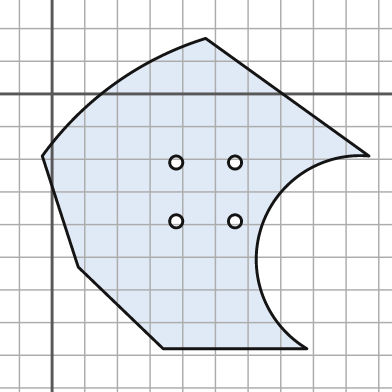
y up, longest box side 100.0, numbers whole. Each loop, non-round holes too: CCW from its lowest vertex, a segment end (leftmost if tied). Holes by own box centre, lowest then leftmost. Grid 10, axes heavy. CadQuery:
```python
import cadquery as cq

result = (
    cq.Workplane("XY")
    .moveTo(34.0, -78.0)
    .lineTo(78.0, -78.0)
    .threePointArc((64.0, -41.0), (97.0, -19.0))
    .lineTo(47.0, 17.0)
    .threePointArc((19.0, 3.0), (-3.0, -19.0))
    .lineTo(8.0, -53.0)
    .close()
    .moveTo(38.0, -39.0)
    .circle(2.0)
    .moveTo(56.0, -39.0)
    .circle(2.0)
    .moveTo(38.0, -21.0)
    .circle(2.0)
    .moveTo(56.0, -21.0)
    .circle(2.0)
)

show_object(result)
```